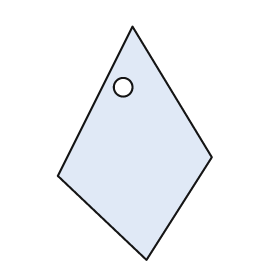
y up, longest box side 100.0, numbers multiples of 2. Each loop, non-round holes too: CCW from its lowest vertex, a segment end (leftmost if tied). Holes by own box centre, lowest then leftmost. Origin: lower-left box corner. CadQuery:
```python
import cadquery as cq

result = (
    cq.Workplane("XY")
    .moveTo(38.0, 0.0)
    .lineTo(66.0, 44.0)
    .lineTo(32.0, 100.0)
    .lineTo(0.0, 36.0)
    .close()
    .moveTo(28.0, 74.0)
    .circle(4.0)
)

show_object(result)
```